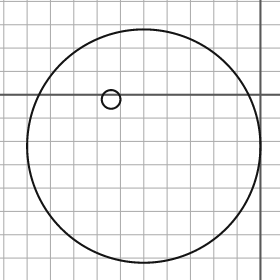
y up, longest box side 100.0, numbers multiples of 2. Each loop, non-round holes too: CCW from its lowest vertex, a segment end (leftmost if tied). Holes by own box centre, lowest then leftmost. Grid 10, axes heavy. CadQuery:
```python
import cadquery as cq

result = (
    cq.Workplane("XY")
    .moveTo(-50.0, -22.0)
    .circle(50.0)
    .moveTo(-64.0, -2.0)
    .circle(4.0)
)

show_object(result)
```